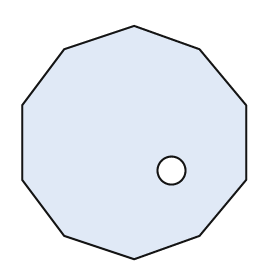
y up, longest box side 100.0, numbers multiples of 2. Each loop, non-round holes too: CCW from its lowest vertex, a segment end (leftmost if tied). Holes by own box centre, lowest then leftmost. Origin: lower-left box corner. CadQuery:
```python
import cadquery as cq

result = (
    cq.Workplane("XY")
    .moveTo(48.0, 0.0)
    .lineTo(76.0, 10.0)
    .lineTo(96.0, 34.0)
    .lineTo(96.0, 66.0)
    .lineTo(76.0, 90.0)
    .lineTo(48.0, 100.0)
    .lineTo(18.0, 90.0)
    .lineTo(0.0, 66.0)
    .lineTo(0.0, 34.0)
    .lineTo(18.0, 10.0)
    .close()
    .moveTo(64.0, 38.0)
    .circle(6.0)
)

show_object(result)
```